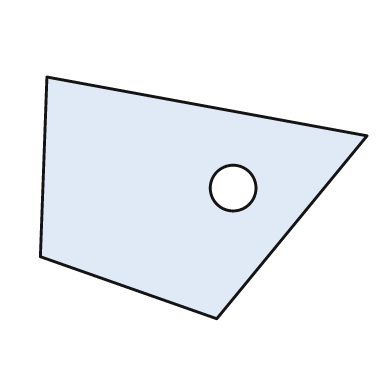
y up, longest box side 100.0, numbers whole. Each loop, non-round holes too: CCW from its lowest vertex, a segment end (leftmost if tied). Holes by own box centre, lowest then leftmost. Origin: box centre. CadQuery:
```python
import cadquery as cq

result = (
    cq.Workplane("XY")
    .moveTo(4.0, -37.0)
    .lineTo(50.0, 19.0)
    .lineTo(-48.0, 37.0)
    .lineTo(-50.0, -18.0)
    .close()
    .moveTo(9.0, 3.0)
    .circle(7.0)
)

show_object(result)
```